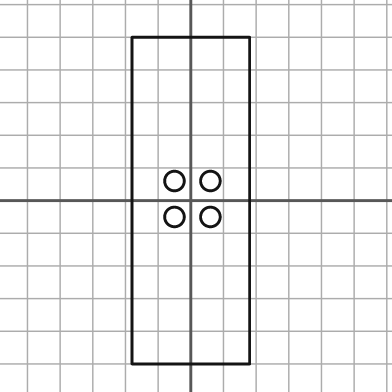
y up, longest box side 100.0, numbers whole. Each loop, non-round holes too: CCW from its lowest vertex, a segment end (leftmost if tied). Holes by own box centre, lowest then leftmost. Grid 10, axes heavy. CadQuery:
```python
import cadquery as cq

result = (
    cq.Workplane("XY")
    .moveTo(-18.0, -50.0)
    .lineTo(18.0, -50.0)
    .lineTo(18.0, 50.0)
    .lineTo(-18.0, 50.0)
    .close()
    .moveTo(-5.0, -5.0)
    .circle(3.0)
    .moveTo(6.0, -5.0)
    .circle(3.0)
    .moveTo(-5.0, 6.0)
    .circle(3.0)
    .moveTo(6.0, 6.0)
    .circle(3.0)
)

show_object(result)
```